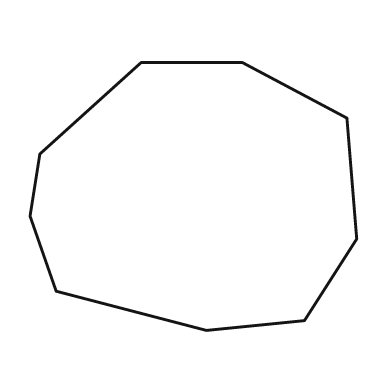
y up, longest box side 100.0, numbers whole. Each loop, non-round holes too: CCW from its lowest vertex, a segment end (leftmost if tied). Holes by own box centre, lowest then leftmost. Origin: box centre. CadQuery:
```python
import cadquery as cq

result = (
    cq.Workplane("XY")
    .moveTo(4.0, -41.0)
    .lineTo(34.0, -38.0)
    .lineTo(50.0, -13.0)
    .lineTo(47.0, 24.0)
    .lineTo(15.0, 41.0)
    .lineTo(-16.0, 41.0)
    .lineTo(-47.0, 13.0)
    .lineTo(-50.0, -6.0)
    .lineTo(-42.0, -29.0)
    .close()
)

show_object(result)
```